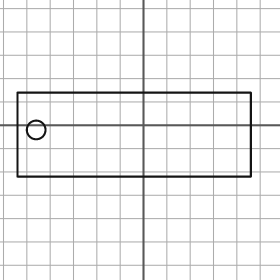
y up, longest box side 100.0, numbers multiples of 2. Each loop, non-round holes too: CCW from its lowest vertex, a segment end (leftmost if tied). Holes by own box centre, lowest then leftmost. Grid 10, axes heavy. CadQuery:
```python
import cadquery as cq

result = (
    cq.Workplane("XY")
    .moveTo(-54.0, -22.0)
    .lineTo(46.0, -22.0)
    .lineTo(46.0, 14.0)
    .lineTo(-54.0, 14.0)
    .close()
    .moveTo(-46.0, -2.0)
    .circle(4.0)
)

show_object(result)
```